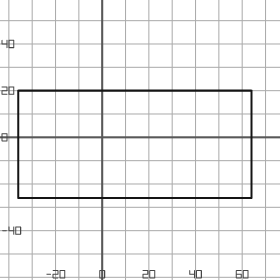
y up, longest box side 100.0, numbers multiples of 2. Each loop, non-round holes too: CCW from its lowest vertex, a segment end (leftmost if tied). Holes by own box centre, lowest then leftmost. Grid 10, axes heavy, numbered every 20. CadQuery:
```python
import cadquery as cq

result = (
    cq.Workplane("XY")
    .moveTo(-36.0, -26.0)
    .lineTo(64.0, -26.0)
    .lineTo(64.0, 20.0)
    .lineTo(-36.0, 20.0)
    .close()
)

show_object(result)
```